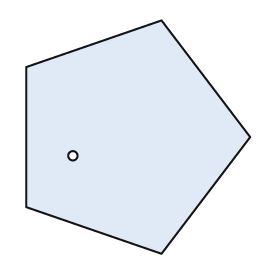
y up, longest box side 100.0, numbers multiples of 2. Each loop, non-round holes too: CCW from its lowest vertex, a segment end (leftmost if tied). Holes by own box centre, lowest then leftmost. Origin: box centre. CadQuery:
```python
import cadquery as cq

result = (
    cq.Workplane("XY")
    .moveTo(10.0, -50.0)
    .lineTo(48.0, 0.0)
    .lineTo(10.0, 50.0)
    .lineTo(-48.0, 30.0)
    .lineTo(-48.0, -30.0)
    .close()
    .moveTo(-28.0, -8.0)
    .circle(2.0)
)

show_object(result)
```